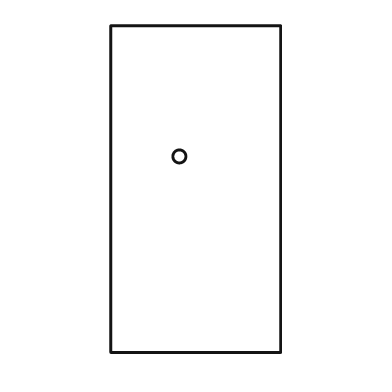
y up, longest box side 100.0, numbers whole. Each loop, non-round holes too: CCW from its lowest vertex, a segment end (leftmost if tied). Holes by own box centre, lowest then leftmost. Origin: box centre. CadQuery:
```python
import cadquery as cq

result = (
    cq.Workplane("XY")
    .moveTo(-26.0, -50.0)
    .lineTo(26.0, -50.0)
    .lineTo(26.0, 50.0)
    .lineTo(-26.0, 50.0)
    .close()
    .moveTo(-5.0, 10.0)
    .circle(2.0)
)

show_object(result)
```